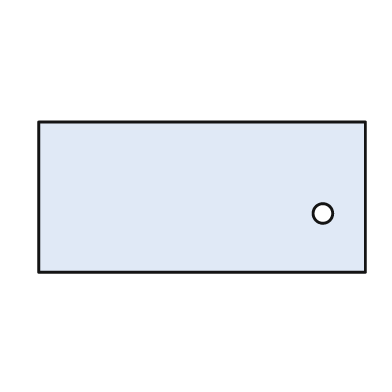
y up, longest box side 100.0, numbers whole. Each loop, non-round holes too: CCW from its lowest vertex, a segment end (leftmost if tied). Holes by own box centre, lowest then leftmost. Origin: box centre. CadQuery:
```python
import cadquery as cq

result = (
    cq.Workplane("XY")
    .moveTo(-50.0, -23.0)
    .lineTo(50.0, -23.0)
    .lineTo(50.0, 23.0)
    .lineTo(-50.0, 23.0)
    .close()
    .moveTo(37.0, -5.0)
    .circle(3.0)
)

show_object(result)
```